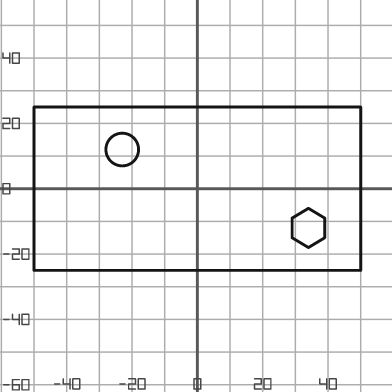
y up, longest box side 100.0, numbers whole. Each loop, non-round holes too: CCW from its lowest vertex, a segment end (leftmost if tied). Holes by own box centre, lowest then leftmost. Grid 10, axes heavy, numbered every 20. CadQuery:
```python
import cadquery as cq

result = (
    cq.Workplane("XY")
    .moveTo(-50.0, -25.0)
    .lineTo(50.0, -25.0)
    .lineTo(50.0, 25.0)
    .lineTo(-50.0, 25.0)
    .close()
    .moveTo(34.0, -18.0)
    .lineTo(39.0, -15.0)
    .lineTo(39.0, -9.0)
    .lineTo(34.0, -6.0)
    .lineTo(29.0, -9.0)
    .lineTo(29.0, -15.0)
    .close()
    .moveTo(-23.0, 12.0)
    .circle(5.0)
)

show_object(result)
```